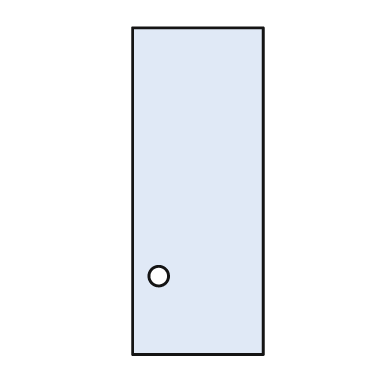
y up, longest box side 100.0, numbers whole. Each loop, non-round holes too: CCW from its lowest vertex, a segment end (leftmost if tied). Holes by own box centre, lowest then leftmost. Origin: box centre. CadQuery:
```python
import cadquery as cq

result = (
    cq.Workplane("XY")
    .moveTo(-20.0, -50.0)
    .lineTo(20.0, -50.0)
    .lineTo(20.0, 50.0)
    .lineTo(-20.0, 50.0)
    .close()
    .moveTo(-12.0, -26.0)
    .circle(3.0)
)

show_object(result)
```